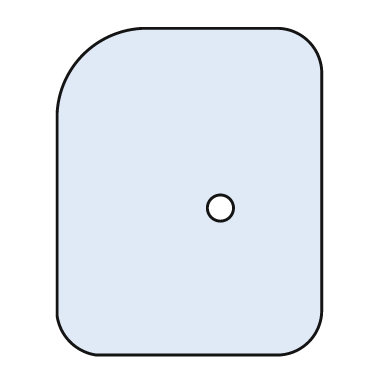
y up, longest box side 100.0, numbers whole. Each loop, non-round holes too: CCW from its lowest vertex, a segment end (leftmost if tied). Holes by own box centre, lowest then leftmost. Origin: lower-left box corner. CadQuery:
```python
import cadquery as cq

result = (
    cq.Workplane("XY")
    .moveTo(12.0, 0.0)
    .lineTo(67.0, 0.0)
    .threePointArc((77.0, 4.0), (81.0, 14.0))
    .lineTo(81.0, 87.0)
    .threePointArc((77.0, 96.0), (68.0, 100.0))
    .lineTo(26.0, 100.0)
    .threePointArc((8.0, 92.0), (0.0, 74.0))
    .lineTo(0.0, 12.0)
    .threePointArc((4.0, 4.0), (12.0, 0.0))
    .close()
    .moveTo(50.0, 45.0)
    .circle(4.0)
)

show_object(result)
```